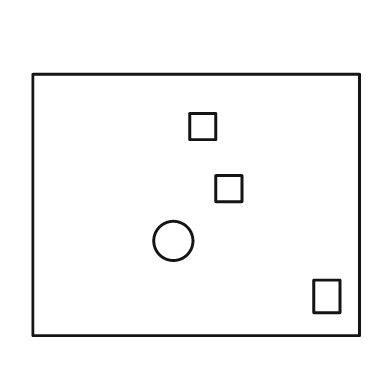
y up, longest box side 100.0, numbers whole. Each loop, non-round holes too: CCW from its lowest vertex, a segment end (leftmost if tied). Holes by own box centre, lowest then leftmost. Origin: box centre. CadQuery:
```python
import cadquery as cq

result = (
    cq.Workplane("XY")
    .moveTo(-50.0, -40.0)
    .lineTo(50.0, -40.0)
    .lineTo(50.0, 40.0)
    .lineTo(-50.0, 40.0)
    .close()
    .moveTo(36.0, -33.0)
    .lineTo(44.0, -33.0)
    .lineTo(44.0, -23.0)
    .lineTo(36.0, -23.0)
    .close()
    .moveTo(-7.0, -11.0)
    .circle(6.0)
    .moveTo(6.0, 1.0)
    .lineTo(14.0, 1.0)
    .lineTo(14.0, 9.0)
    .lineTo(6.0, 9.0)
    .close()
    .moveTo(-2.0, 20.0)
    .lineTo(6.0, 20.0)
    .lineTo(6.0, 28.0)
    .lineTo(-2.0, 28.0)
    .close()
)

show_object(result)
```